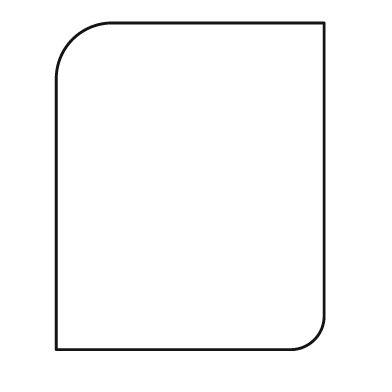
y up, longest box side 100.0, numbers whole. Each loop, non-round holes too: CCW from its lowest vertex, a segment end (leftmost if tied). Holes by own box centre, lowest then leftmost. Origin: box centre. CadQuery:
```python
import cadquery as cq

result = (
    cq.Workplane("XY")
    .moveTo(-41.0, -50.0)
    .lineTo(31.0, -50.0)
    .threePointArc((38.0, -47.0), (41.0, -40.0))
    .lineTo(41.0, 50.0)
    .lineTo(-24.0, 50.0)
    .threePointArc((-36.0, 45.0), (-41.0, 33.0))
    .close()
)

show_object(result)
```